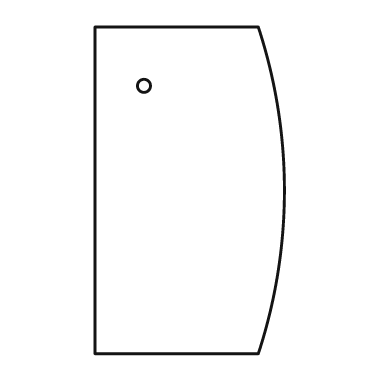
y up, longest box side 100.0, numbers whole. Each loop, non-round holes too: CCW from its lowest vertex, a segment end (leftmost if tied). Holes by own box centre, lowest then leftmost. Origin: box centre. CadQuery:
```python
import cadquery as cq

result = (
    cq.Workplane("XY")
    .moveTo(-29.0, -50.0)
    .lineTo(21.0, -50.0)
    .threePointArc((29.0, 0.0), (21.0, 50.0))
    .lineTo(-29.0, 50.0)
    .close()
    .moveTo(-14.0, 32.0)
    .circle(2.0)
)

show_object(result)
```